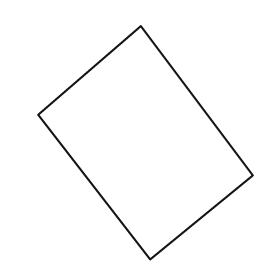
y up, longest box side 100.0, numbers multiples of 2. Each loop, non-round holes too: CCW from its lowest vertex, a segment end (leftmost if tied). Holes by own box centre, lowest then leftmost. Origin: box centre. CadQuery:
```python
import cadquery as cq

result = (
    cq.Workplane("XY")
    .moveTo(2.0, -50.0)
    .lineTo(46.0, -14.0)
    .lineTo(-2.0, 50.0)
    .lineTo(-46.0, 12.0)
    .close()
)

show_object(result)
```